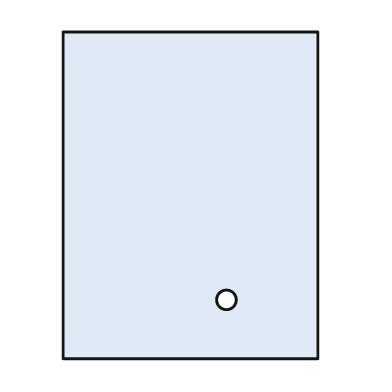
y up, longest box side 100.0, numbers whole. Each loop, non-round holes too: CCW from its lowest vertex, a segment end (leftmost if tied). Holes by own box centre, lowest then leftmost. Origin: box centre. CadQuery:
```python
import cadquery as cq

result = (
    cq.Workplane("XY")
    .moveTo(-39.0, -50.0)
    .lineTo(39.0, -50.0)
    .lineTo(39.0, 50.0)
    .lineTo(-39.0, 50.0)
    .close()
    .moveTo(11.0, -32.0)
    .circle(3.0)
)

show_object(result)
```